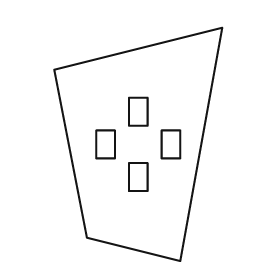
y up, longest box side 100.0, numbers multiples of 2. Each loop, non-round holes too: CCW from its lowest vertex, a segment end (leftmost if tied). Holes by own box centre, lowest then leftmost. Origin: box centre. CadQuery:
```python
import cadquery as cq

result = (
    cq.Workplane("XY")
    .moveTo(18.0, -50.0)
    .lineTo(36.0, 50.0)
    .lineTo(-36.0, 32.0)
    .lineTo(-22.0, -40.0)
    .close()
    .moveTo(-4.0, -20.0)
    .lineTo(4.0, -20.0)
    .lineTo(4.0, -8.0)
    .lineTo(-4.0, -8.0)
    .close()
    .moveTo(-18.0, -6.0)
    .lineTo(-10.0, -6.0)
    .lineTo(-10.0, 6.0)
    .lineTo(-18.0, 6.0)
    .close()
    .moveTo(10.0, -6.0)
    .lineTo(18.0, -6.0)
    .lineTo(18.0, 6.0)
    .lineTo(10.0, 6.0)
    .close()
    .moveTo(-4.0, 8.0)
    .lineTo(4.0, 8.0)
    .lineTo(4.0, 20.0)
    .lineTo(-4.0, 20.0)
    .close()
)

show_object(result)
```